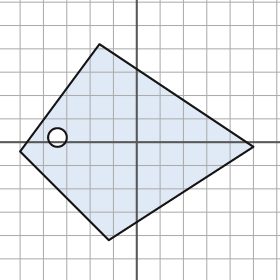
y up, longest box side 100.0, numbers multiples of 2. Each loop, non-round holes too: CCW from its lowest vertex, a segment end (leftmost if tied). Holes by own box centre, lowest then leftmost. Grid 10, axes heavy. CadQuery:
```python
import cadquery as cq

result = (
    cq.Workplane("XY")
    .moveTo(-12.0, -42.0)
    .lineTo(50.0, -2.0)
    .lineTo(-16.0, 42.0)
    .lineTo(-50.0, -4.0)
    .close()
    .moveTo(-34.0, 2.0)
    .circle(4.0)
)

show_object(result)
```